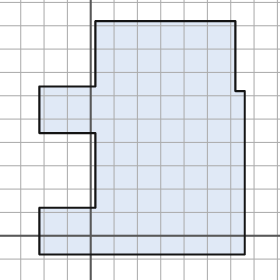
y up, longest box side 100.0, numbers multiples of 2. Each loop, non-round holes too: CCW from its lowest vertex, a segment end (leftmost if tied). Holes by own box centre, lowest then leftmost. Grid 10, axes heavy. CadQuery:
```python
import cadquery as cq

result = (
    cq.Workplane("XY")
    .moveTo(-22.0, -8.0)
    .lineTo(66.0, -8.0)
    .lineTo(66.0, 62.0)
    .lineTo(62.0, 62.0)
    .lineTo(62.0, 92.0)
    .lineTo(2.0, 92.0)
    .lineTo(2.0, 64.0)
    .lineTo(-22.0, 64.0)
    .lineTo(-22.0, 44.0)
    .lineTo(2.0, 44.0)
    .lineTo(2.0, 12.0)
    .lineTo(-22.0, 12.0)
    .close()
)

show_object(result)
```